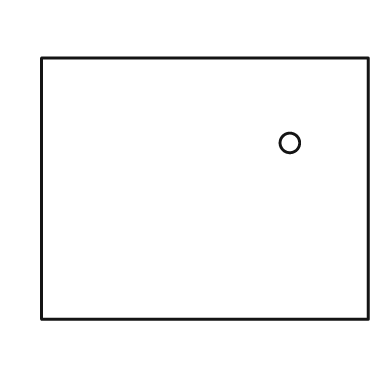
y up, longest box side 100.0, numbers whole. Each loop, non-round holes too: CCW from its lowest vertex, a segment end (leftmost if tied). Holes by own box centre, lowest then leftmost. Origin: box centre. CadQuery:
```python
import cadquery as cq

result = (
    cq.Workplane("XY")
    .moveTo(-50.0, -40.0)
    .lineTo(50.0, -40.0)
    .lineTo(50.0, 40.0)
    .lineTo(-50.0, 40.0)
    .close()
    .moveTo(26.0, 14.0)
    .circle(3.0)
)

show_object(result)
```